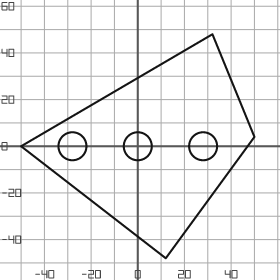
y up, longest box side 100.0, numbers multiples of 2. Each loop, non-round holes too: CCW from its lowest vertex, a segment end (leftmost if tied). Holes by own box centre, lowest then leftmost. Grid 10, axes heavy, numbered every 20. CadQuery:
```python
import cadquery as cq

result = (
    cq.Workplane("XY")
    .moveTo(12.0, -48.0)
    .lineTo(50.0, 4.0)
    .lineTo(32.0, 48.0)
    .lineTo(-50.0, 0.0)
    .close()
    .moveTo(-28.0, 0.0)
    .circle(6.0)
    .moveTo(0.0, 0.0)
    .circle(6.0)
    .moveTo(28.0, 0.0)
    .circle(6.0)
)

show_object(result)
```